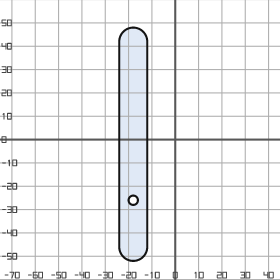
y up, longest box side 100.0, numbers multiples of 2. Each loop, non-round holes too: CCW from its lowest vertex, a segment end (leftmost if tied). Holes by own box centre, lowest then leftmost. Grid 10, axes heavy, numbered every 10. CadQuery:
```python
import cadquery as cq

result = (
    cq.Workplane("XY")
    .moveTo(-24.0, -46.0)
    .threePointArc((-18.0, -52.0), (-12.0, -46.0))
    .lineTo(-12.0, 42.0)
    .threePointArc((-18.0, 48.0), (-24.0, 42.0))
    .close()
    .moveTo(-18.0, -26.0)
    .circle(2.0)
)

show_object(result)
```